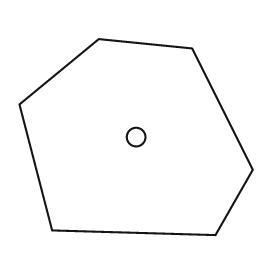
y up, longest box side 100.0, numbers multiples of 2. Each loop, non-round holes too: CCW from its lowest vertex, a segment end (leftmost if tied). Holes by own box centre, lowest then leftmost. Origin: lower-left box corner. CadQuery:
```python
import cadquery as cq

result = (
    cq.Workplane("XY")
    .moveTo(84.0, 0.0)
    .lineTo(100.0, 28.0)
    .lineTo(74.0, 80.0)
    .lineTo(34.0, 84.0)
    .lineTo(0.0, 56.0)
    .lineTo(14.0, 2.0)
    .close()
    .moveTo(50.0, 42.0)
    .circle(4.0)
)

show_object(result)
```